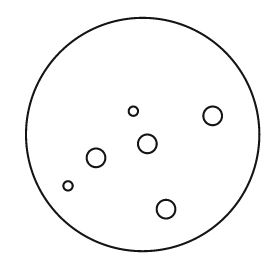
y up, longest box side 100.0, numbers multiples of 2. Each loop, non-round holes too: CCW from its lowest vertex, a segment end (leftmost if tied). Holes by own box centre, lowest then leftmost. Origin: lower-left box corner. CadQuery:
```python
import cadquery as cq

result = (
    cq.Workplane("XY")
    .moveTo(50.0, 50.0)
    .circle(50.0)
    .moveTo(60.0, 18.0)
    .circle(4.0)
    .moveTo(18.0, 28.0)
    .circle(2.0)
    .moveTo(30.0, 40.0)
    .circle(4.0)
    .moveTo(52.0, 46.0)
    .circle(4.0)
    .moveTo(80.0, 58.0)
    .circle(4.0)
    .moveTo(46.0, 60.0)
    .circle(2.0)
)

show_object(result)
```